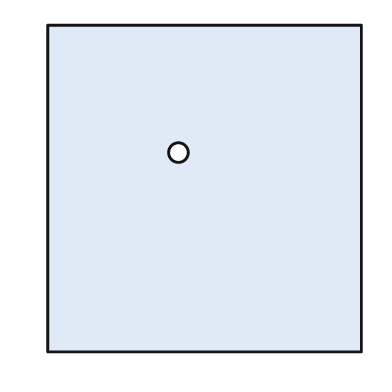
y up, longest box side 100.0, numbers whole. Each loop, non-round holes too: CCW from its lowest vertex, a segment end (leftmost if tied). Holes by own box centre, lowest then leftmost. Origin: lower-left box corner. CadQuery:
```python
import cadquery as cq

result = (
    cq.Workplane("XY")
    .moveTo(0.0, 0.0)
    .lineTo(96.0, 0.0)
    .lineTo(96.0, 100.0)
    .lineTo(0.0, 100.0)
    .close()
    .moveTo(40.0, 61.0)
    .circle(3.0)
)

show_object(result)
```